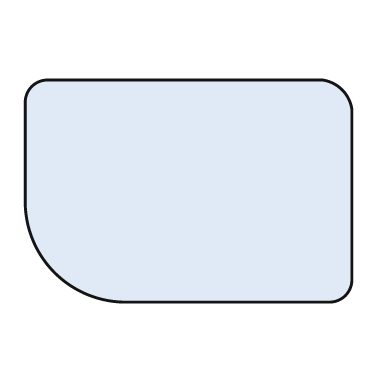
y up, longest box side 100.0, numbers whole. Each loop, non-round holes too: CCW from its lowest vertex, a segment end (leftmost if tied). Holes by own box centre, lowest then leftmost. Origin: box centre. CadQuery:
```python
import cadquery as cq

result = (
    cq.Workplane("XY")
    .moveTo(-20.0, -34.0)
    .lineTo(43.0, -34.0)
    .threePointArc((48.0, -32.0), (50.0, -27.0))
    .lineTo(50.0, 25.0)
    .threePointArc((47.0, 31.0), (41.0, 34.0))
    .lineTo(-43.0, 34.0)
    .threePointArc((-48.0, 32.0), (-50.0, 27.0))
    .lineTo(-50.0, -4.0)
    .threePointArc((-41.0, -25.0), (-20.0, -34.0))
    .close()
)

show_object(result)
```